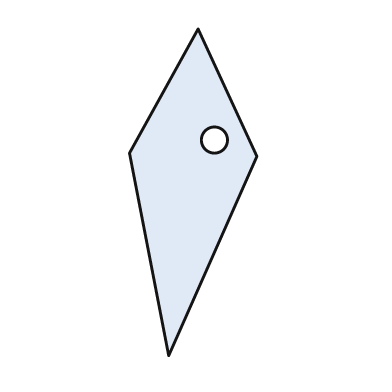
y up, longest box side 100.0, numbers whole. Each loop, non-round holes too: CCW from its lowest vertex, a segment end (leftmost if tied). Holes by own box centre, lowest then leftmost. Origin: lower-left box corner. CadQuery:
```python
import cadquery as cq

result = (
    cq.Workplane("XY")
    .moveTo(12.0, 0.0)
    .lineTo(39.0, 61.0)
    .lineTo(21.0, 100.0)
    .lineTo(0.0, 62.0)
    .close()
    .moveTo(26.0, 66.0)
    .circle(4.0)
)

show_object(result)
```